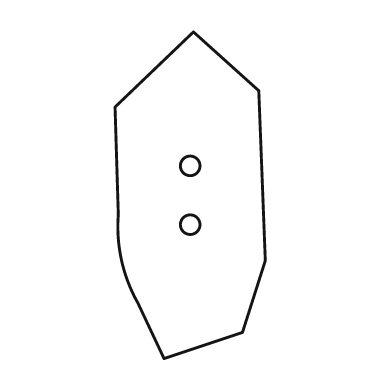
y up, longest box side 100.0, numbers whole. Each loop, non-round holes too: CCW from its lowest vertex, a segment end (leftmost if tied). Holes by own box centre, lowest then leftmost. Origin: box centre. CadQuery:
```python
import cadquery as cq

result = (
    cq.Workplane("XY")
    .moveTo(-8.0, -50.0)
    .lineTo(16.0, -42.0)
    .lineTo(23.0, -20.0)
    .lineTo(21.0, 32.0)
    .lineTo(1.0, 50.0)
    .lineTo(-23.0, 27.0)
    .lineTo(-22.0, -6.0)
    .threePointArc((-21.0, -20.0), (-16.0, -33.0))
    .close()
    .moveTo(0.0, -9.0)
    .circle(3.0)
    .moveTo(0.0, 9.0)
    .circle(3.0)
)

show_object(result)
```